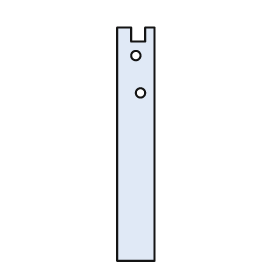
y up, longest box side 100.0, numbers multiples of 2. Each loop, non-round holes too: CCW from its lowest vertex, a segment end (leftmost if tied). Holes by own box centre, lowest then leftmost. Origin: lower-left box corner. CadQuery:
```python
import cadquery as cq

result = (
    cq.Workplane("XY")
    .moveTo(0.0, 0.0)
    .lineTo(16.0, 0.0)
    .lineTo(16.0, 100.0)
    .lineTo(12.0, 100.0)
    .lineTo(12.0, 94.0)
    .lineTo(6.0, 94.0)
    .lineTo(6.0, 100.0)
    .lineTo(0.0, 100.0)
    .close()
    .moveTo(10.0, 72.0)
    .circle(2.0)
    .moveTo(8.0, 88.0)
    .circle(2.0)
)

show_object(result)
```